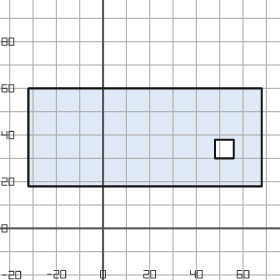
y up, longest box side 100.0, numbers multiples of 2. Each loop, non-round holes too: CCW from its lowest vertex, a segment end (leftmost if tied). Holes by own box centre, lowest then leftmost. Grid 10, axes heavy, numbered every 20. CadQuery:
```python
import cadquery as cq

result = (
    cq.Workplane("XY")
    .moveTo(-32.0, 18.0)
    .lineTo(68.0, 18.0)
    .lineTo(68.0, 60.0)
    .lineTo(-32.0, 60.0)
    .close()
    .moveTo(48.0, 30.0)
    .lineTo(56.0, 30.0)
    .lineTo(56.0, 38.0)
    .lineTo(48.0, 38.0)
    .close()
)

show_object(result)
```